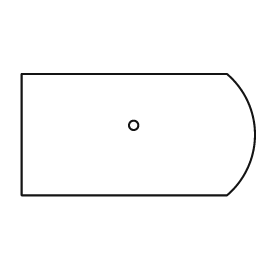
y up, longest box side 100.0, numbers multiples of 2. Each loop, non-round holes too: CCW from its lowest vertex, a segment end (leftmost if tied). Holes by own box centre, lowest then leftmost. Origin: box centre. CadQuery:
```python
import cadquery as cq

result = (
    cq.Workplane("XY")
    .moveTo(-50.0, -26.0)
    .lineTo(38.0, -26.0)
    .threePointArc((50.0, 0.0), (38.0, 26.0))
    .lineTo(-50.0, 26.0)
    .close()
    .moveTo(-2.0, 4.0)
    .circle(2.0)
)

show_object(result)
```